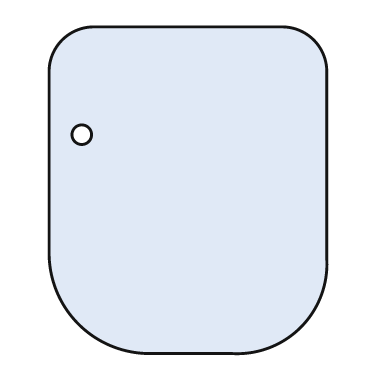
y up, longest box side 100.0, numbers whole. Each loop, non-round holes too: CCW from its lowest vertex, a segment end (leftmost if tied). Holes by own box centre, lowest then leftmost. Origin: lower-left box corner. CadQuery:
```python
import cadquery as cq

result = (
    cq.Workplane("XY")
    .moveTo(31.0, 0.0)
    .lineTo(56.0, 0.0)
    .threePointArc((77.0, 8.0), (85.0, 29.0))
    .lineTo(85.0, 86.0)
    .threePointArc((81.0, 96.0), (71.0, 100.0))
    .lineTo(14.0, 100.0)
    .threePointArc((4.0, 96.0), (0.0, 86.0))
    .lineTo(0.0, 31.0)
    .threePointArc((9.0, 9.0), (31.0, 0.0))
    .close()
    .moveTo(10.0, 67.0)
    .circle(3.0)
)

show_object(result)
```